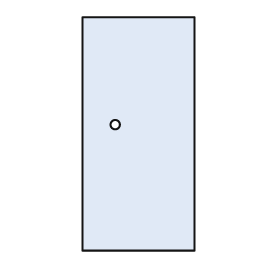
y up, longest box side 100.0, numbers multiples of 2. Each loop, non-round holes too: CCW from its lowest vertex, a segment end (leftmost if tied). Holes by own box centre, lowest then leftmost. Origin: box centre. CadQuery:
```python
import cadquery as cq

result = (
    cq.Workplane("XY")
    .moveTo(-24.0, -50.0)
    .lineTo(24.0, -50.0)
    .lineTo(24.0, 50.0)
    .lineTo(-24.0, 50.0)
    .close()
    .moveTo(-10.0, 4.0)
    .circle(2.0)
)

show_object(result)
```